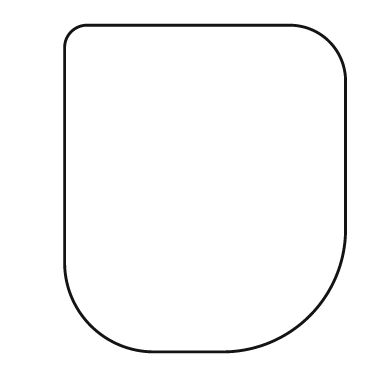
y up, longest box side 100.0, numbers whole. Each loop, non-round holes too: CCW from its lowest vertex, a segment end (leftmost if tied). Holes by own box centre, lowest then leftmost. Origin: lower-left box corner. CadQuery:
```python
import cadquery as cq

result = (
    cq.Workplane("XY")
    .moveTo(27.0, 0.0)
    .lineTo(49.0, 0.0)
    .threePointArc((75.0, 11.0), (86.0, 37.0))
    .lineTo(86.0, 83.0)
    .threePointArc((81.0, 95.0), (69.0, 100.0))
    .lineTo(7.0, 100.0)
    .threePointArc((2.0, 98.0), (0.0, 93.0))
    .lineTo(0.0, 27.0)
    .threePointArc((8.0, 8.0), (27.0, 0.0))
    .close()
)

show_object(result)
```